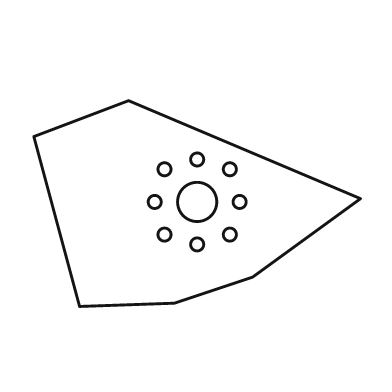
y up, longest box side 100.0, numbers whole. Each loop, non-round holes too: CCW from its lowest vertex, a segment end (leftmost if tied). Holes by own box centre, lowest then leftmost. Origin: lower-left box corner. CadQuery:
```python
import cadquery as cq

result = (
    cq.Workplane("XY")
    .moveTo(14.0, 0.0)
    .lineTo(43.0, 1.0)
    .lineTo(67.0, 9.0)
    .lineTo(100.0, 33.0)
    .lineTo(29.0, 63.0)
    .lineTo(0.0, 52.0)
    .close()
    .moveTo(50.0, 19.0)
    .circle(2.0)
    .moveTo(40.0, 22.0)
    .circle(2.0)
    .moveTo(60.0, 22.0)
    .circle(2.0)
    .moveTo(37.0, 32.0)
    .circle(2.0)
    .moveTo(50.0, 32.0)
    .circle(6.0)
    .moveTo(63.0, 32.0)
    .circle(2.0)
    .moveTo(40.0, 42.0)
    .circle(2.0)
    .moveTo(60.0, 42.0)
    .circle(2.0)
    .moveTo(50.0, 45.0)
    .circle(2.0)
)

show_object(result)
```